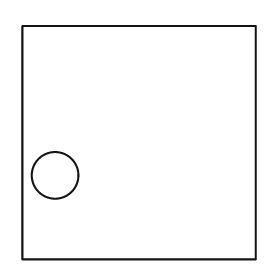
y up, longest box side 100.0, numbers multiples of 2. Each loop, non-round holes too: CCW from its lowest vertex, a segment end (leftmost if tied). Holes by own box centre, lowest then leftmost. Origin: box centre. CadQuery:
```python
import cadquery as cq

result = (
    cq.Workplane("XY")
    .moveTo(-50.0, -50.0)
    .lineTo(50.0, -50.0)
    .lineTo(50.0, 50.0)
    .lineTo(-50.0, 50.0)
    .close()
    .moveTo(-36.0, -14.0)
    .circle(10.0)
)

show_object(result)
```